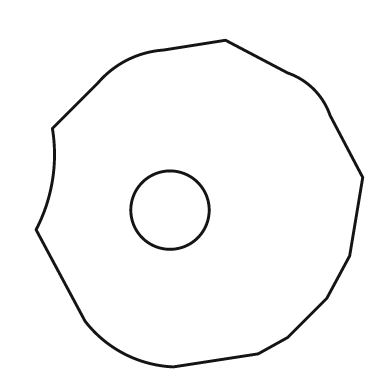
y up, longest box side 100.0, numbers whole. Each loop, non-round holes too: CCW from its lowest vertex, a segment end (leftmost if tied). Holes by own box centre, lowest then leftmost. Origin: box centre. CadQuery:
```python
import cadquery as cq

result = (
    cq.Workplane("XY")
    .moveTo(-8.0, -50.0)
    .lineTo(18.0, -46.0)
    .lineTo(27.0, -41.0)
    .lineTo(39.0, -29.0)
    .lineTo(46.0, -16.0)
    .lineTo(50.0, 8.0)
    .lineTo(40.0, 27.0)
    .threePointArc((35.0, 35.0), (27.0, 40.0))
    .lineTo(8.0, 50.0)
    .lineTo(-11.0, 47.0)
    .threePointArc((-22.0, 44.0), (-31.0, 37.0))
    .lineTo(-45.0, 23.0)
    .threePointArc((-45.0, 7.0), (-50.0, -8.0))
    .lineTo(-35.0, -36.0)
    .threePointArc((-23.0, -46.0), (-8.0, -50.0))
    .close()
    .moveTo(-9.0, -2.0)
    .circle(12.0)
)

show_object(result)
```